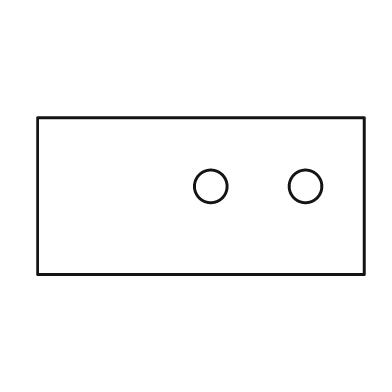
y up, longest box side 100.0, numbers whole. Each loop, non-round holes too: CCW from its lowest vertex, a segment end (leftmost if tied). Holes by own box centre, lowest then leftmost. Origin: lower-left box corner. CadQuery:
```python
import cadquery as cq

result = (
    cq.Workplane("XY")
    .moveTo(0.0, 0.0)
    .lineTo(100.0, 0.0)
    .lineTo(100.0, 48.0)
    .lineTo(0.0, 48.0)
    .close()
    .moveTo(53.0, 27.0)
    .circle(5.0)
    .moveTo(82.0, 27.0)
    .circle(5.0)
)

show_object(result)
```